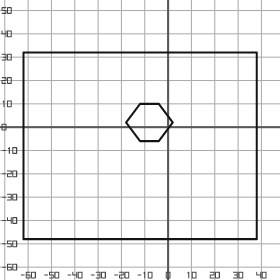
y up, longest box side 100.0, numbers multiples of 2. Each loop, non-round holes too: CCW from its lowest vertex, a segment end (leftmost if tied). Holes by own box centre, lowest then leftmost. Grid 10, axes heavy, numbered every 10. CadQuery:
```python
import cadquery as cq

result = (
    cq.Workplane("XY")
    .moveTo(-62.0, -48.0)
    .lineTo(38.0, -48.0)
    .lineTo(38.0, 32.0)
    .lineTo(-62.0, 32.0)
    .close()
    .moveTo(-12.0, -6.0)
    .lineTo(-4.0, -6.0)
    .lineTo(2.0, 2.0)
    .lineTo(-4.0, 10.0)
    .lineTo(-12.0, 10.0)
    .lineTo(-18.0, 2.0)
    .close()
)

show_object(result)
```